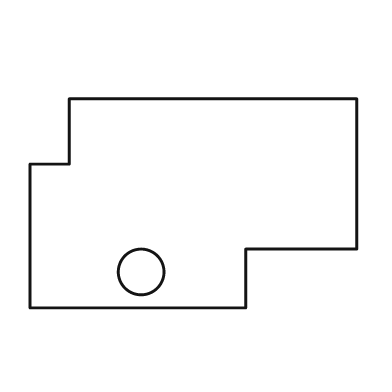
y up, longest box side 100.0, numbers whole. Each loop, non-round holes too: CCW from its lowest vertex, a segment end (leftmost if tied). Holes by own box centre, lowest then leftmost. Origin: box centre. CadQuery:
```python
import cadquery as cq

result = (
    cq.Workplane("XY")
    .moveTo(-50.0, -32.0)
    .lineTo(16.0, -32.0)
    .lineTo(16.0, -14.0)
    .lineTo(50.0, -14.0)
    .lineTo(50.0, 32.0)
    .lineTo(-38.0, 32.0)
    .lineTo(-38.0, 12.0)
    .lineTo(-50.0, 12.0)
    .close()
    .moveTo(-16.0, -21.0)
    .circle(7.0)
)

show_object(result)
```